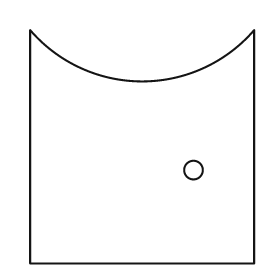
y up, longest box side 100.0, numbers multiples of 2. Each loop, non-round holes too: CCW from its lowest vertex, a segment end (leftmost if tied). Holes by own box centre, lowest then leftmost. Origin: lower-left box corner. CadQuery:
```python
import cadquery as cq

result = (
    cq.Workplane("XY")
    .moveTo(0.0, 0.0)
    .lineTo(96.0, 0.0)
    .lineTo(96.0, 100.0)
    .threePointArc((48.0, 78.0), (0.0, 100.0))
    .close()
    .moveTo(70.0, 40.0)
    .circle(4.0)
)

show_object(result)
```